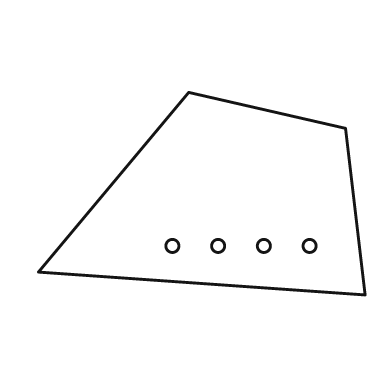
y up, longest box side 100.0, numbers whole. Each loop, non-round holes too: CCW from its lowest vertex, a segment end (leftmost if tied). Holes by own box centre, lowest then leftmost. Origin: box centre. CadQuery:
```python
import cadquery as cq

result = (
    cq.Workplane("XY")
    .moveTo(50.0, -31.0)
    .lineTo(44.0, 20.0)
    .lineTo(-4.0, 31.0)
    .lineTo(-50.0, -24.0)
    .close()
    .moveTo(-9.0, -16.0)
    .circle(2.0)
    .moveTo(5.0, -16.0)
    .circle(2.0)
    .moveTo(19.0, -16.0)
    .circle(2.0)
    .moveTo(33.0, -16.0)
    .circle(2.0)
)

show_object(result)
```